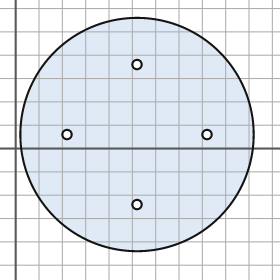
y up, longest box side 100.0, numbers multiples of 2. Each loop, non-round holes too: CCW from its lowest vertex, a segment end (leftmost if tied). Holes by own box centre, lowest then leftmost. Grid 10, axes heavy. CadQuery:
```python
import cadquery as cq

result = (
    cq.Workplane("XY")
    .moveTo(52.0, 6.0)
    .circle(50.0)
    .moveTo(52.0, -24.0)
    .circle(2.0)
    .moveTo(22.0, 6.0)
    .circle(2.0)
    .moveTo(82.0, 6.0)
    .circle(2.0)
    .moveTo(52.0, 36.0)
    .circle(2.0)
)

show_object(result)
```